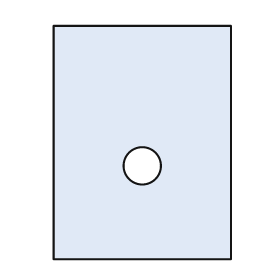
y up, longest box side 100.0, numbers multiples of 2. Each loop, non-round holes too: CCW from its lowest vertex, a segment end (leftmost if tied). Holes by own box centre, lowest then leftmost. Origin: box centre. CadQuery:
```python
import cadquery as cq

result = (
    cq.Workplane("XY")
    .moveTo(-38.0, -50.0)
    .lineTo(38.0, -50.0)
    .lineTo(38.0, 50.0)
    .lineTo(-38.0, 50.0)
    .close()
    .moveTo(0.0, -10.0)
    .circle(8.0)
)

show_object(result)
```